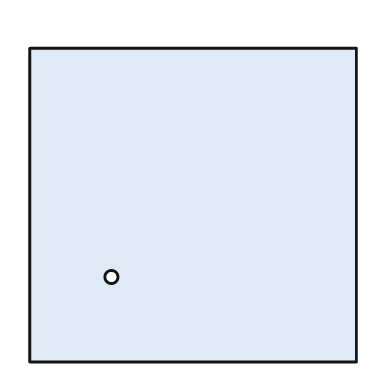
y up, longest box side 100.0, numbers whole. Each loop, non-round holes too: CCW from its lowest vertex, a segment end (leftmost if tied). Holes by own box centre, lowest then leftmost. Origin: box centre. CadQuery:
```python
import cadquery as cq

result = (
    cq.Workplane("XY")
    .moveTo(-50.0, -48.0)
    .lineTo(50.0, -48.0)
    .lineTo(50.0, 48.0)
    .lineTo(-50.0, 48.0)
    .close()
    .moveTo(-25.0, -22.0)
    .circle(2.0)
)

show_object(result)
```